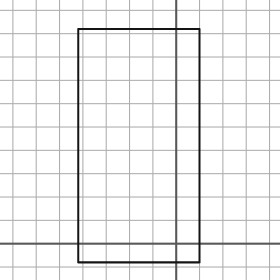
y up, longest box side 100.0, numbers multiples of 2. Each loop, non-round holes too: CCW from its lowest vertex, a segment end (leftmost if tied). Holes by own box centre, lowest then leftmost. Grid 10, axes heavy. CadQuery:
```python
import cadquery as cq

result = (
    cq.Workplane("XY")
    .moveTo(-42.0, -8.0)
    .lineTo(10.0, -8.0)
    .lineTo(10.0, 92.0)
    .lineTo(-42.0, 92.0)
    .close()
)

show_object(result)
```